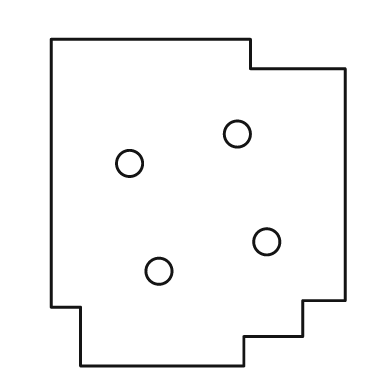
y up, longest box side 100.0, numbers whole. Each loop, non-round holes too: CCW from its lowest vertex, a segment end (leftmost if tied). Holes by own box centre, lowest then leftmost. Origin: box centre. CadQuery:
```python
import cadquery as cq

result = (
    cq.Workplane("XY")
    .moveTo(-36.0, -50.0)
    .lineTo(14.0, -50.0)
    .lineTo(14.0, -41.0)
    .lineTo(32.0, -41.0)
    .lineTo(32.0, -30.0)
    .lineTo(45.0, -30.0)
    .lineTo(45.0, 41.0)
    .lineTo(16.0, 41.0)
    .lineTo(16.0, 50.0)
    .lineTo(-45.0, 50.0)
    .lineTo(-45.0, -32.0)
    .lineTo(-36.0, -32.0)
    .close()
    .moveTo(-12.0, -21.0)
    .circle(4.0)
    .moveTo(21.0, -12.0)
    .circle(4.0)
    .moveTo(-21.0, 12.0)
    .circle(4.0)
    .moveTo(12.0, 21.0)
    .circle(4.0)
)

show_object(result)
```